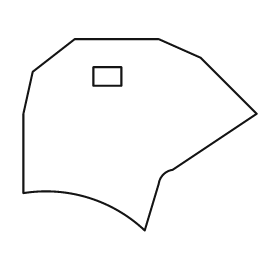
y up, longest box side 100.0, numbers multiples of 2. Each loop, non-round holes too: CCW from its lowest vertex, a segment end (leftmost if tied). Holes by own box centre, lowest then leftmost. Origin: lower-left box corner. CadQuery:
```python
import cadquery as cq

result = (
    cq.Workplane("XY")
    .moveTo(52.0, 0.0)
    .lineTo(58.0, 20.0)
    .threePointArc((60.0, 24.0), (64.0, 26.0))
    .lineTo(100.0, 50.0)
    .lineTo(76.0, 74.0)
    .lineTo(58.0, 82.0)
    .lineTo(22.0, 82.0)
    .lineTo(4.0, 68.0)
    .lineTo(0.0, 50.0)
    .lineTo(0.0, 16.0)
    .threePointArc((28.0, 14.0), (52.0, 0.0))
    .close()
    .moveTo(30.0, 62.0)
    .lineTo(42.0, 62.0)
    .lineTo(42.0, 70.0)
    .lineTo(30.0, 70.0)
    .close()
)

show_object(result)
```